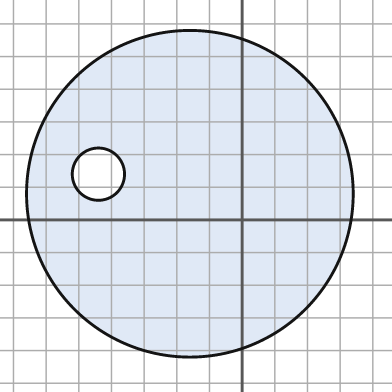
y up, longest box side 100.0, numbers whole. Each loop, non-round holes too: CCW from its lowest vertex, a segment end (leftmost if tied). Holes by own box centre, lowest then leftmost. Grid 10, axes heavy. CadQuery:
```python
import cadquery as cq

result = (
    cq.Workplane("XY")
    .moveTo(-16.0, 8.0)
    .circle(50.0)
    .moveTo(-44.0, 14.0)
    .circle(8.0)
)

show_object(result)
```